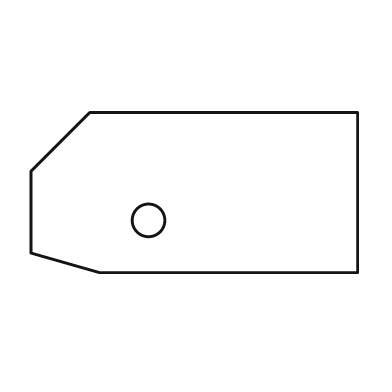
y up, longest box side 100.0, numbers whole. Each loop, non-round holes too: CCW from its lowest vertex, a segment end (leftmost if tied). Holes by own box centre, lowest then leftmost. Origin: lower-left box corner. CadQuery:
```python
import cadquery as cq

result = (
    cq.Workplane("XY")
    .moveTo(21.0, 0.0)
    .lineTo(100.0, 0.0)
    .lineTo(100.0, 49.0)
    .lineTo(18.0, 49.0)
    .lineTo(0.0, 31.0)
    .lineTo(0.0, 6.0)
    .close()
    .moveTo(36.0, 16.0)
    .circle(5.0)
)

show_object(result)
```